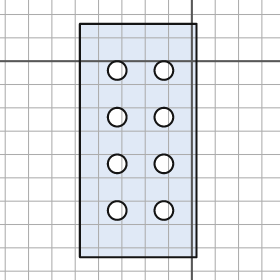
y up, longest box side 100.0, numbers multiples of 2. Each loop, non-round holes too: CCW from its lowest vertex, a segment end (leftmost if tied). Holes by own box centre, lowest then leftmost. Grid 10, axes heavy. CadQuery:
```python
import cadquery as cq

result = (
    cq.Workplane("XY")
    .moveTo(-48.0, -84.0)
    .lineTo(2.0, -84.0)
    .lineTo(2.0, 16.0)
    .lineTo(-48.0, 16.0)
    .close()
    .moveTo(-32.0, -64.0)
    .circle(4.0)
    .moveTo(-12.0, -64.0)
    .circle(4.0)
    .moveTo(-32.0, -44.0)
    .circle(4.0)
    .moveTo(-12.0, -44.0)
    .circle(4.0)
    .moveTo(-32.0, -24.0)
    .circle(4.0)
    .moveTo(-12.0, -24.0)
    .circle(4.0)
    .moveTo(-32.0, -4.0)
    .circle(4.0)
    .moveTo(-12.0, -4.0)
    .circle(4.0)
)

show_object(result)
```